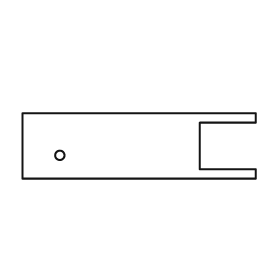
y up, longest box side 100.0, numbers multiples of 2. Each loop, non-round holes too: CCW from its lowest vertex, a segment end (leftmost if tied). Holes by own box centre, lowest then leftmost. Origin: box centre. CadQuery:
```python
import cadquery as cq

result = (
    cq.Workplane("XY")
    .moveTo(-50.0, -14.0)
    .lineTo(50.0, -14.0)
    .lineTo(50.0, -10.0)
    .lineTo(26.0, -10.0)
    .lineTo(26.0, 10.0)
    .lineTo(50.0, 10.0)
    .lineTo(50.0, 14.0)
    .lineTo(-50.0, 14.0)
    .close()
    .moveTo(-34.0, -4.0)
    .circle(2.0)
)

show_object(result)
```